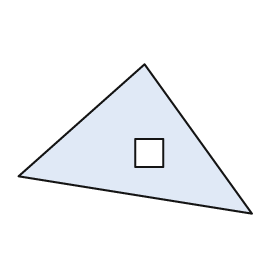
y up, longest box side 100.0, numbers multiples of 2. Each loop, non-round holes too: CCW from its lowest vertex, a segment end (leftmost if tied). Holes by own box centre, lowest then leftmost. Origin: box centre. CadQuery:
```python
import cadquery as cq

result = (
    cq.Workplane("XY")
    .moveTo(50.0, -32.0)
    .lineTo(4.0, 32.0)
    .lineTo(-50.0, -16.0)
    .close()
    .moveTo(0.0, -12.0)
    .lineTo(12.0, -12.0)
    .lineTo(12.0, 0.0)
    .lineTo(0.0, 0.0)
    .close()
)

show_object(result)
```